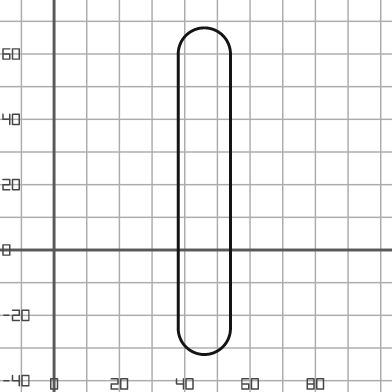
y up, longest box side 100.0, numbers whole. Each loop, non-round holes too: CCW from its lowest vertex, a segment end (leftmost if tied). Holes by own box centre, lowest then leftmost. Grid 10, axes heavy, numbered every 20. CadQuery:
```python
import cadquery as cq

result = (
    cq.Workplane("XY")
    .moveTo(38.0, -24.0)
    .threePointArc((46.0, -32.0), (54.0, -24.0))
    .lineTo(54.0, 60.0)
    .threePointArc((46.0, 68.0), (38.0, 60.0))
    .close()
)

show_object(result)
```